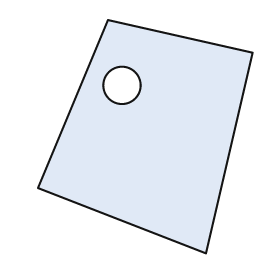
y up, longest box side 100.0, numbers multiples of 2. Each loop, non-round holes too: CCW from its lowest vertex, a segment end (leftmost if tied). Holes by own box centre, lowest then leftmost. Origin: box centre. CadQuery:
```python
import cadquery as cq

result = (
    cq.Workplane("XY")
    .moveTo(26.0, -50.0)
    .lineTo(46.0, 36.0)
    .lineTo(-16.0, 50.0)
    .lineTo(-46.0, -22.0)
    .close()
    .moveTo(-10.0, 22.0)
    .circle(8.0)
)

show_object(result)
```